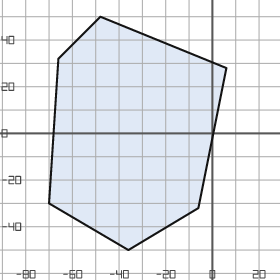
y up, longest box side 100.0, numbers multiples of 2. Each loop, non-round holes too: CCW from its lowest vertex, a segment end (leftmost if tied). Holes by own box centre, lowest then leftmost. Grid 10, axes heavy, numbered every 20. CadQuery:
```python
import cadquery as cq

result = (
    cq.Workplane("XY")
    .moveTo(-36.0, -50.0)
    .lineTo(-6.0, -32.0)
    .lineTo(6.0, 28.0)
    .lineTo(-48.0, 50.0)
    .lineTo(-66.0, 32.0)
    .lineTo(-70.0, -30.0)
    .close()
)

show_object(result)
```